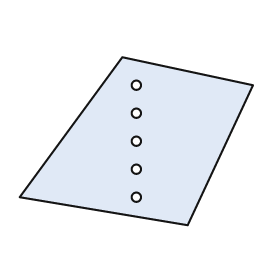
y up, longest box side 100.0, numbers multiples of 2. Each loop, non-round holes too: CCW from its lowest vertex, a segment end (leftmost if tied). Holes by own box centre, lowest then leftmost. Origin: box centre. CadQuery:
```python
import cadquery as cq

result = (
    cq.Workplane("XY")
    .moveTo(22.0, -36.0)
    .lineTo(50.0, 24.0)
    .lineTo(-6.0, 36.0)
    .lineTo(-50.0, -24.0)
    .close()
    .moveTo(0.0, -24.0)
    .circle(2.0)
    .moveTo(0.0, -12.0)
    .circle(2.0)
    .moveTo(0.0, 0.0)
    .circle(2.0)
    .moveTo(0.0, 12.0)
    .circle(2.0)
    .moveTo(0.0, 24.0)
    .circle(2.0)
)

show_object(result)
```